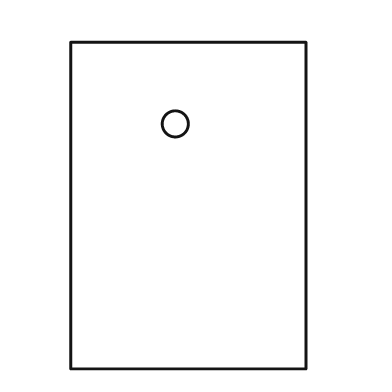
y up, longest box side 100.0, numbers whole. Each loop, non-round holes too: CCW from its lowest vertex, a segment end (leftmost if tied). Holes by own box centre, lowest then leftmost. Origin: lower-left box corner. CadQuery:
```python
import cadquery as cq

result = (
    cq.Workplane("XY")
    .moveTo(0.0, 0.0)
    .lineTo(72.0, 0.0)
    .lineTo(72.0, 100.0)
    .lineTo(0.0, 100.0)
    .close()
    .moveTo(32.0, 75.0)
    .circle(4.0)
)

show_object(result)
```